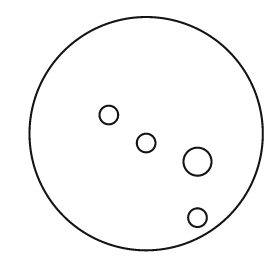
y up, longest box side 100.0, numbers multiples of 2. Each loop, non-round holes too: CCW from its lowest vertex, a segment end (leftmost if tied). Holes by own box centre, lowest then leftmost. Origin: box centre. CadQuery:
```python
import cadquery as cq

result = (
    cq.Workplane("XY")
    .moveTo(0.0, 0.0)
    .circle(50.0)
    .moveTo(22.0, -36.0)
    .circle(4.0)
    .moveTo(22.0, -12.0)
    .circle(6.0)
    .moveTo(0.0, -4.0)
    .circle(4.0)
    .moveTo(-16.0, 8.0)
    .circle(4.0)
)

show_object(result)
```